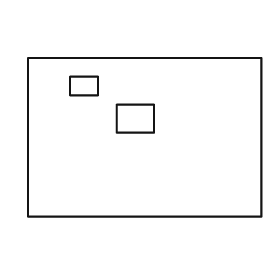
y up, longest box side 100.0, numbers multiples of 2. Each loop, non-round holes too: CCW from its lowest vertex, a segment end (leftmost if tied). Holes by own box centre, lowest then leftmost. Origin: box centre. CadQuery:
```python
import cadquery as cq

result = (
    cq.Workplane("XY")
    .moveTo(-50.0, -34.0)
    .lineTo(50.0, -34.0)
    .lineTo(50.0, 34.0)
    .lineTo(-50.0, 34.0)
    .close()
    .moveTo(-12.0, 2.0)
    .lineTo(4.0, 2.0)
    .lineTo(4.0, 14.0)
    .lineTo(-12.0, 14.0)
    .close()
    .moveTo(-32.0, 18.0)
    .lineTo(-20.0, 18.0)
    .lineTo(-20.0, 26.0)
    .lineTo(-32.0, 26.0)
    .close()
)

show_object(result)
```